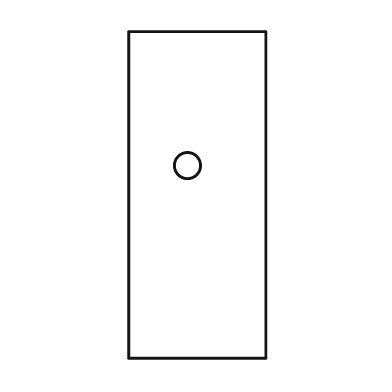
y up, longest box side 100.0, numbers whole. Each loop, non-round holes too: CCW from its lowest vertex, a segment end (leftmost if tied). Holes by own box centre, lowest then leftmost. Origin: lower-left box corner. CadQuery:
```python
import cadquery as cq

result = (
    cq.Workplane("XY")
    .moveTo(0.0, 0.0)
    .lineTo(42.0, 0.0)
    .lineTo(42.0, 100.0)
    .lineTo(0.0, 100.0)
    .close()
    .moveTo(18.0, 59.0)
    .circle(4.0)
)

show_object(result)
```